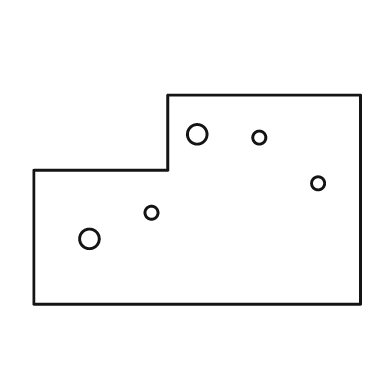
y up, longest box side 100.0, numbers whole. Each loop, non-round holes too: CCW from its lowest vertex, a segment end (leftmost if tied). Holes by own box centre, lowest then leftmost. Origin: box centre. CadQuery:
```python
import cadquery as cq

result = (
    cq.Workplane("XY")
    .moveTo(-50.0, -32.0)
    .lineTo(50.0, -32.0)
    .lineTo(50.0, 32.0)
    .lineTo(-9.0, 32.0)
    .lineTo(-9.0, 9.0)
    .lineTo(-50.0, 9.0)
    .close()
    .moveTo(-33.0, -12.0)
    .circle(3.0)
    .moveTo(-14.0, -4.0)
    .circle(2.0)
    .moveTo(37.0, 5.0)
    .circle(2.0)
    .moveTo(19.0, 19.0)
    .circle(2.0)
    .moveTo(0.0, 20.0)
    .circle(3.0)
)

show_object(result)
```